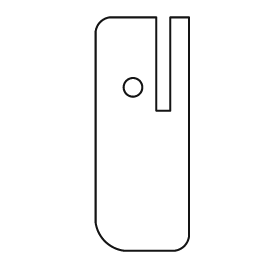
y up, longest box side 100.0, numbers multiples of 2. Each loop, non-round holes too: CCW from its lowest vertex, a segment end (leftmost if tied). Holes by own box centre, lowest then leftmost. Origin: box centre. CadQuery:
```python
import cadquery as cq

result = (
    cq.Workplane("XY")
    .moveTo(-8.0, -50.0)
    .lineTo(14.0, -50.0)
    .threePointArc((18.0, -48.0), (20.0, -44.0))
    .lineTo(20.0, 50.0)
    .lineTo(12.0, 50.0)
    .lineTo(12.0, 10.0)
    .lineTo(6.0, 10.0)
    .lineTo(6.0, 50.0)
    .lineTo(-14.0, 50.0)
    .threePointArc((-18.0, 48.0), (-20.0, 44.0))
    .lineTo(-20.0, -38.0)
    .threePointArc((-16.0, -46.0), (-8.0, -50.0))
    .close()
    .moveTo(-4.0, 20.0)
    .circle(4.0)
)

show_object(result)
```